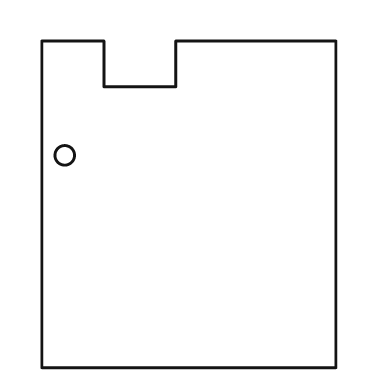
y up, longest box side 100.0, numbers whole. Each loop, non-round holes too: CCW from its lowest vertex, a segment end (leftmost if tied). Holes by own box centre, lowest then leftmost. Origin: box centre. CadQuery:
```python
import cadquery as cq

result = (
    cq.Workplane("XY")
    .moveTo(-45.0, -50.0)
    .lineTo(45.0, -50.0)
    .lineTo(45.0, 50.0)
    .lineTo(-4.0, 50.0)
    .lineTo(-4.0, 36.0)
    .lineTo(-26.0, 36.0)
    .lineTo(-26.0, 50.0)
    .lineTo(-45.0, 50.0)
    .close()
    .moveTo(-38.0, 15.0)
    .circle(3.0)
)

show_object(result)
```